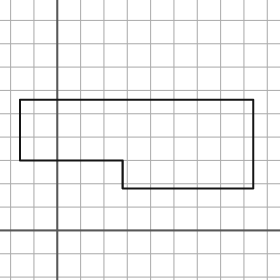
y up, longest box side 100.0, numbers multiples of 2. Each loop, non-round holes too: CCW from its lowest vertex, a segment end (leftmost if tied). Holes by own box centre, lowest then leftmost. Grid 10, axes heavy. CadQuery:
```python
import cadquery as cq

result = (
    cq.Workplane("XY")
    .moveTo(28.0, 18.0)
    .lineTo(84.0, 18.0)
    .lineTo(84.0, 56.0)
    .lineTo(-16.0, 56.0)
    .lineTo(-16.0, 30.0)
    .lineTo(28.0, 30.0)
    .close()
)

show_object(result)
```